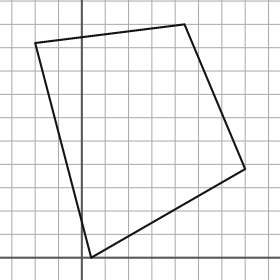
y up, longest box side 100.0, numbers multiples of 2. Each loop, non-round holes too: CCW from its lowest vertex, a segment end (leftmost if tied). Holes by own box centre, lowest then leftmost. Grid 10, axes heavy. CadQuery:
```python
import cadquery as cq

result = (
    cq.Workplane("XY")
    .moveTo(4.0, 0.0)
    .lineTo(70.0, 38.0)
    .lineTo(44.0, 100.0)
    .lineTo(-20.0, 92.0)
    .close()
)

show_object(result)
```